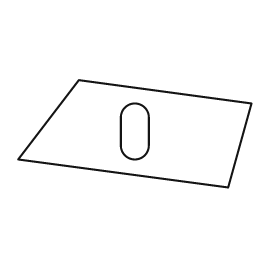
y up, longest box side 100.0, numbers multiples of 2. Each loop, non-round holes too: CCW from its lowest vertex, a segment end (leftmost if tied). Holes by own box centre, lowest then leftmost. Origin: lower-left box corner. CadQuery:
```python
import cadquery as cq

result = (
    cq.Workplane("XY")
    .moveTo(90.0, 0.0)
    .lineTo(100.0, 36.0)
    .lineTo(26.0, 46.0)
    .lineTo(0.0, 12.0)
    .close()
    .moveTo(44.0, 18.0)
    .threePointArc((50.0, 12.0), (56.0, 18.0))
    .lineTo(56.0, 30.0)
    .threePointArc((50.0, 36.0), (44.0, 30.0))
    .close()
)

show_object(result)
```